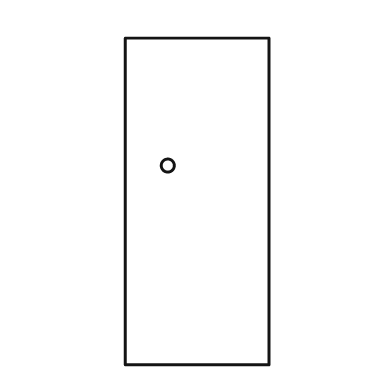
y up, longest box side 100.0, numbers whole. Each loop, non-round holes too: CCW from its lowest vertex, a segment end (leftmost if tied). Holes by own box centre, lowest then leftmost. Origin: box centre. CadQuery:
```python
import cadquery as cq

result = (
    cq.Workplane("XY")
    .moveTo(-22.0, -50.0)
    .lineTo(22.0, -50.0)
    .lineTo(22.0, 50.0)
    .lineTo(-22.0, 50.0)
    .close()
    .moveTo(-9.0, 11.0)
    .circle(2.0)
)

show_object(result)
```